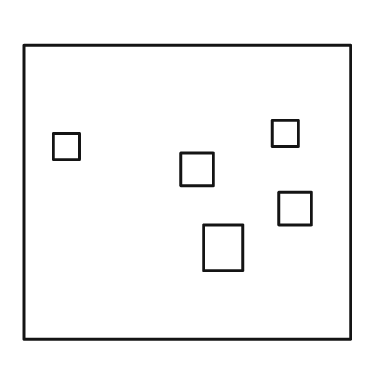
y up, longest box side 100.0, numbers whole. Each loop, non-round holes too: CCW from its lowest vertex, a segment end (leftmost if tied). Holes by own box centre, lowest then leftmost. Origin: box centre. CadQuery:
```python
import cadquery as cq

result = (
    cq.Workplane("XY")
    .moveTo(-50.0, -45.0)
    .lineTo(50.0, -45.0)
    .lineTo(50.0, 45.0)
    .lineTo(-50.0, 45.0)
    .close()
    .moveTo(5.0, -24.0)
    .lineTo(17.0, -24.0)
    .lineTo(17.0, -10.0)
    .lineTo(5.0, -10.0)
    .close()
    .moveTo(28.0, -10.0)
    .lineTo(38.0, -10.0)
    .lineTo(38.0, 0.0)
    .lineTo(28.0, 0.0)
    .close()
    .moveTo(-2.0, 2.0)
    .lineTo(8.0, 2.0)
    .lineTo(8.0, 12.0)
    .lineTo(-2.0, 12.0)
    .close()
    .moveTo(-41.0, 10.0)
    .lineTo(-33.0, 10.0)
    .lineTo(-33.0, 18.0)
    .lineTo(-41.0, 18.0)
    .close()
    .moveTo(26.0, 14.0)
    .lineTo(34.0, 14.0)
    .lineTo(34.0, 22.0)
    .lineTo(26.0, 22.0)
    .close()
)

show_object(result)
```